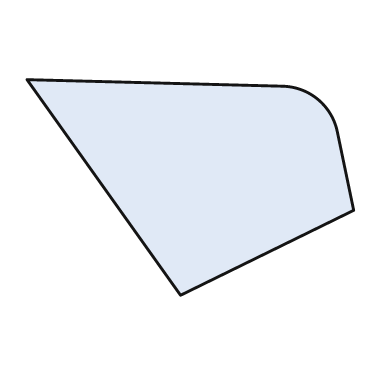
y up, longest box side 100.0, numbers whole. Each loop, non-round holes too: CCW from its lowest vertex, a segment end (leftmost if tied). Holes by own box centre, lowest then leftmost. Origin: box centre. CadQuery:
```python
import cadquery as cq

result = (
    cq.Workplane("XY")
    .moveTo(-3.0, -33.0)
    .lineTo(50.0, -7.0)
    .lineTo(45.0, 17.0)
    .threePointArc((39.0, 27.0), (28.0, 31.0))
    .lineTo(-50.0, 33.0)
    .close()
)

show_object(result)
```